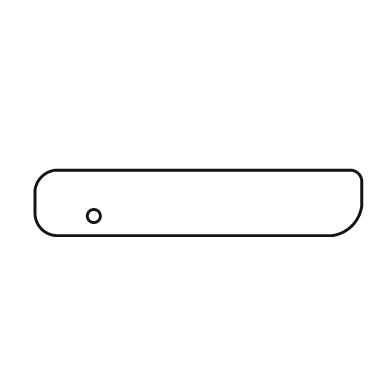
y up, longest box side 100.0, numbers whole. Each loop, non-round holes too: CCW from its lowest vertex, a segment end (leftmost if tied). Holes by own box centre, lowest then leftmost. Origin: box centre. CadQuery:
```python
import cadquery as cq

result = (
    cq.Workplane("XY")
    .moveTo(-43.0, -10.0)
    .lineTo(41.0, -10.0)
    .threePointArc((47.0, -7.0), (50.0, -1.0))
    .lineTo(50.0, 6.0)
    .threePointArc((49.0, 9.0), (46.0, 10.0))
    .lineTo(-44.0, 10.0)
    .threePointArc((-48.0, 8.0), (-50.0, 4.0))
    .lineTo(-50.0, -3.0)
    .threePointArc((-48.0, -8.0), (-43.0, -10.0))
    .close()
    .moveTo(-32.0, -4.0)
    .circle(2.0)
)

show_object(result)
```